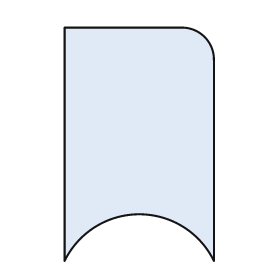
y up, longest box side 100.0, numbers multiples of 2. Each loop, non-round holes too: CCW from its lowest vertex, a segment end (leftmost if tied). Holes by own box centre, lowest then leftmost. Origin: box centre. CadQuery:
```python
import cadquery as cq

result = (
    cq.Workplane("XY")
    .moveTo(-32.0, -50.0)
    .threePointArc((0.0, -30.0), (32.0, -50.0))
    .lineTo(32.0, 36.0)
    .threePointArc((28.0, 46.0), (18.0, 50.0))
    .lineTo(-32.0, 50.0)
    .close()
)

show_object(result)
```